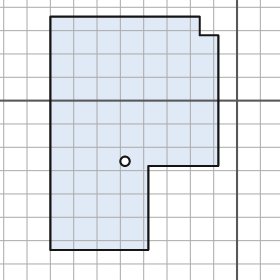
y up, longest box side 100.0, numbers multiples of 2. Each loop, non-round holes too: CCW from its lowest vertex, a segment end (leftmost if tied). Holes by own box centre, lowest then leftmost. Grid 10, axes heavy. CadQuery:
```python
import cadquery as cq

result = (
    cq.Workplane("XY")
    .moveTo(-80.0, -64.0)
    .lineTo(-38.0, -64.0)
    .lineTo(-38.0, -28.0)
    .lineTo(-8.0, -28.0)
    .lineTo(-8.0, 28.0)
    .lineTo(-16.0, 28.0)
    .lineTo(-16.0, 36.0)
    .lineTo(-80.0, 36.0)
    .close()
    .moveTo(-48.0, -26.0)
    .circle(2.0)
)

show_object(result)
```